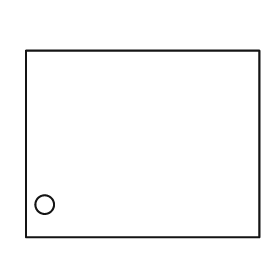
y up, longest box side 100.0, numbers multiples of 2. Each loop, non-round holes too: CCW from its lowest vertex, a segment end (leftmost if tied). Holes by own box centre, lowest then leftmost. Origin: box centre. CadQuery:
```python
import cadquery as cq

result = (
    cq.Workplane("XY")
    .moveTo(-50.0, -40.0)
    .lineTo(50.0, -40.0)
    .lineTo(50.0, 40.0)
    .lineTo(-50.0, 40.0)
    .close()
    .moveTo(-42.0, -26.0)
    .circle(4.0)
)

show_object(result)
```